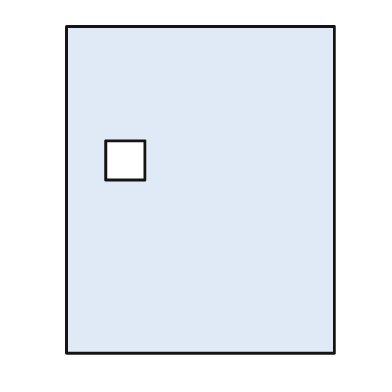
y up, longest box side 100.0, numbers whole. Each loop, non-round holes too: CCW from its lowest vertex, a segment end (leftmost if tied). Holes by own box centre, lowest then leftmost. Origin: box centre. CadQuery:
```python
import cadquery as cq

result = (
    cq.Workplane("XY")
    .moveTo(-41.0, -50.0)
    .lineTo(41.0, -50.0)
    .lineTo(41.0, 50.0)
    .lineTo(-41.0, 50.0)
    .close()
    .moveTo(-29.0, 3.0)
    .lineTo(-17.0, 3.0)
    .lineTo(-17.0, 15.0)
    .lineTo(-29.0, 15.0)
    .close()
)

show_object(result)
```